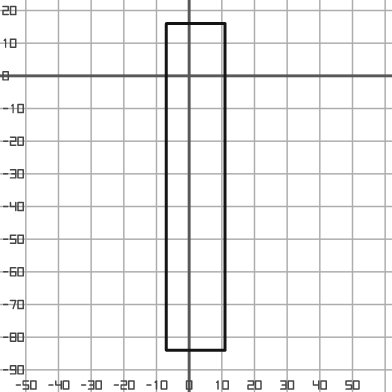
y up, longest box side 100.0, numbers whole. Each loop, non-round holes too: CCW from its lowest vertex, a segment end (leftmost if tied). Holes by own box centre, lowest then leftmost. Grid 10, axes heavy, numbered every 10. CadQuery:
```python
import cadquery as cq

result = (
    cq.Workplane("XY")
    .moveTo(-7.0, -84.0)
    .lineTo(11.0, -84.0)
    .lineTo(11.0, 16.0)
    .lineTo(-7.0, 16.0)
    .close()
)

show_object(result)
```